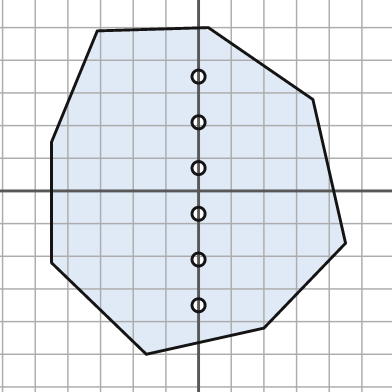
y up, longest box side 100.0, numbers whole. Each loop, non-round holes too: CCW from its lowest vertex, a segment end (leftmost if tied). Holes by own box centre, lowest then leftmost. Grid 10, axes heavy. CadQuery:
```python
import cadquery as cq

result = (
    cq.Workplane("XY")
    .moveTo(-16.0, -50.0)
    .lineTo(20.0, -42.0)
    .lineTo(45.0, -16.0)
    .lineTo(35.0, 28.0)
    .lineTo(3.0, 50.0)
    .lineTo(-31.0, 49.0)
    .lineTo(-45.0, 15.0)
    .lineTo(-45.0, -22.0)
    .close()
    .moveTo(0.0, -35.0)
    .circle(2.0)
    .moveTo(0.0, -21.0)
    .circle(2.0)
    .moveTo(0.0, -7.0)
    .circle(2.0)
    .moveTo(0.0, 7.0)
    .circle(2.0)
    .moveTo(0.0, 21.0)
    .circle(2.0)
    .moveTo(0.0, 35.0)
    .circle(2.0)
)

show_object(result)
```